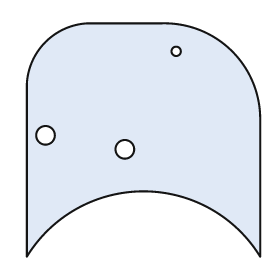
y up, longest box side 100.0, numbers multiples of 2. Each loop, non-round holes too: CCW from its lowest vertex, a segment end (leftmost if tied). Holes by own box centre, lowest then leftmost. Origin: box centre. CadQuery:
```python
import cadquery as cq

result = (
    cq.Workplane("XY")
    .moveTo(-50.0, -50.0)
    .threePointArc((0.0, -22.0), (50.0, -50.0))
    .lineTo(50.0, 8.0)
    .threePointArc((38.0, 38.0), (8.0, 50.0))
    .lineTo(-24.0, 50.0)
    .threePointArc((-42.0, 42.0), (-50.0, 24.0))
    .close()
    .moveTo(-8.0, -4.0)
    .circle(4.0)
    .moveTo(-42.0, 2.0)
    .circle(4.0)
    .moveTo(14.0, 38.0)
    .circle(2.0)
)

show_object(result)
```